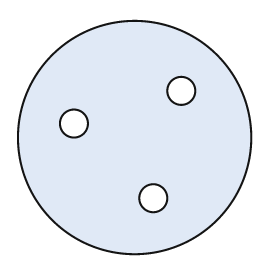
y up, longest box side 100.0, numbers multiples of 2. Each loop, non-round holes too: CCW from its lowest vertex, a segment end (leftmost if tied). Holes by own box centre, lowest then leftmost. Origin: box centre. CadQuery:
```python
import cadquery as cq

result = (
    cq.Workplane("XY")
    .moveTo(0.0, 0.0)
    .circle(50.0)
    .moveTo(8.0, -26.0)
    .circle(6.0)
    .moveTo(-26.0, 6.0)
    .circle(6.0)
    .moveTo(20.0, 20.0)
    .circle(6.0)
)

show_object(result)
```